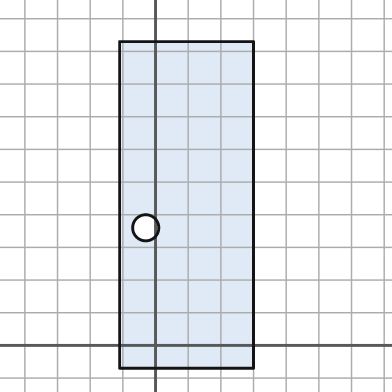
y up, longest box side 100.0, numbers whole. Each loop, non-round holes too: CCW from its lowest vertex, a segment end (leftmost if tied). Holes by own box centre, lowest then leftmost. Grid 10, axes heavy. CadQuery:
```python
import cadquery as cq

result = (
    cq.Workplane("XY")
    .moveTo(-11.0, -7.0)
    .lineTo(30.0, -7.0)
    .lineTo(30.0, 93.0)
    .lineTo(-11.0, 93.0)
    .close()
    .moveTo(-3.0, 36.0)
    .circle(4.0)
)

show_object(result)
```